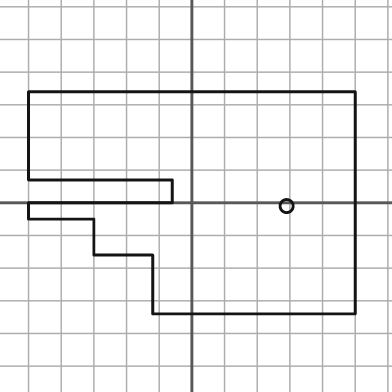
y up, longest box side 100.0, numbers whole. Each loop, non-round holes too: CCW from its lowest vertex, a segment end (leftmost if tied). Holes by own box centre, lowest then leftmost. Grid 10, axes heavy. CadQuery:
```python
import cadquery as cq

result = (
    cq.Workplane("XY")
    .moveTo(-12.0, -34.0)
    .lineTo(50.0, -34.0)
    .lineTo(50.0, 34.0)
    .lineTo(-50.0, 34.0)
    .lineTo(-50.0, 7.0)
    .lineTo(-6.0, 7.0)
    .lineTo(-6.0, 0.0)
    .lineTo(-50.0, 0.0)
    .lineTo(-50.0, -5.0)
    .lineTo(-30.0, -5.0)
    .lineTo(-30.0, -16.0)
    .lineTo(-12.0, -16.0)
    .close()
    .moveTo(29.0, -1.0)
    .circle(2.0)
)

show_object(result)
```